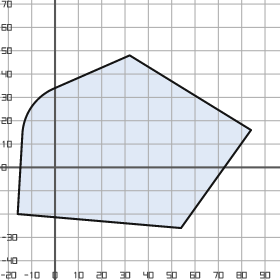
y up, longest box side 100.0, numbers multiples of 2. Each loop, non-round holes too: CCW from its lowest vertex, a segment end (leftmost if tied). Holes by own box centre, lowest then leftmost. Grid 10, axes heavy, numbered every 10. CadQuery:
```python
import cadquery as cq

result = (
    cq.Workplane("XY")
    .moveTo(54.0, -26.0)
    .lineTo(84.0, 16.0)
    .lineTo(32.0, 48.0)
    .lineTo(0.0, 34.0)
    .threePointArc((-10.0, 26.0), (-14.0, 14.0))
    .lineTo(-16.0, -20.0)
    .close()
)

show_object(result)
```